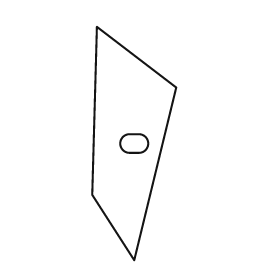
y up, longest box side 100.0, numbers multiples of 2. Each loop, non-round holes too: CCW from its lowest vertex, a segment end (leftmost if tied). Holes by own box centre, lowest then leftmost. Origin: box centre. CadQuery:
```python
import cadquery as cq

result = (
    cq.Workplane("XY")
    .moveTo(0.0, -50.0)
    .lineTo(18.0, 24.0)
    .lineTo(-16.0, 50.0)
    .lineTo(-18.0, -22.0)
    .close()
    .moveTo(-2.0, -4.0)
    .lineTo(2.0, -4.0)
    .threePointArc((6.0, 0.0), (2.0, 4.0))
    .lineTo(-2.0, 4.0)
    .threePointArc((-6.0, 0.0), (-2.0, -4.0))
    .close()
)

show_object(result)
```